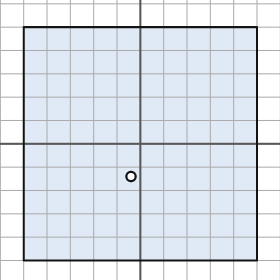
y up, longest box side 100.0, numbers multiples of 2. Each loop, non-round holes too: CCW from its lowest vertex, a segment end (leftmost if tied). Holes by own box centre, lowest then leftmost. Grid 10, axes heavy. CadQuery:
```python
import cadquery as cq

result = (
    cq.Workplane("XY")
    .moveTo(-50.0, -50.0)
    .lineTo(50.0, -50.0)
    .lineTo(50.0, 50.0)
    .lineTo(-50.0, 50.0)
    .close()
    .moveTo(-4.0, -14.0)
    .circle(2.0)
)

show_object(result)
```